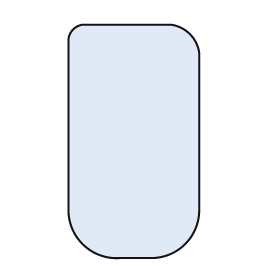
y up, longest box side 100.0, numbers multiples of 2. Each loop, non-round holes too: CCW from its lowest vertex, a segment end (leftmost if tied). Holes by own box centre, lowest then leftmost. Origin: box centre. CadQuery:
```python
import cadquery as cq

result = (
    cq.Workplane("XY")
    .moveTo(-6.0, -50.0)
    .lineTo(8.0, -50.0)
    .threePointArc((22.0, -44.0), (28.0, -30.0))
    .lineTo(28.0, 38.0)
    .threePointArc((24.0, 46.0), (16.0, 50.0))
    .lineTo(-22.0, 50.0)
    .threePointArc((-26.0, 48.0), (-28.0, 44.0))
    .lineTo(-28.0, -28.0)
    .threePointArc((-22.0, -44.0), (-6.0, -50.0))
    .close()
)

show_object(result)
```